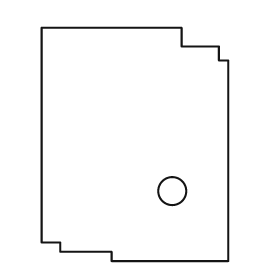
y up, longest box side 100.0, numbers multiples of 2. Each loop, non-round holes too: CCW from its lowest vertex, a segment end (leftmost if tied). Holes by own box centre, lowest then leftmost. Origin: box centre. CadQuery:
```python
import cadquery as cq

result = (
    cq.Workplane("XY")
    .moveTo(-10.0, -50.0)
    .lineTo(40.0, -50.0)
    .lineTo(40.0, 36.0)
    .lineTo(36.0, 36.0)
    .lineTo(36.0, 42.0)
    .lineTo(20.0, 42.0)
    .lineTo(20.0, 50.0)
    .lineTo(-40.0, 50.0)
    .lineTo(-40.0, -42.0)
    .lineTo(-32.0, -42.0)
    .lineTo(-32.0, -46.0)
    .lineTo(-10.0, -46.0)
    .close()
    .moveTo(16.0, -20.0)
    .circle(6.0)
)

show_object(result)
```